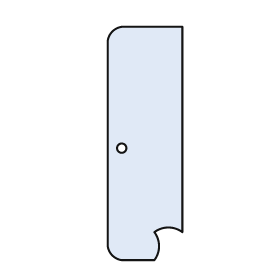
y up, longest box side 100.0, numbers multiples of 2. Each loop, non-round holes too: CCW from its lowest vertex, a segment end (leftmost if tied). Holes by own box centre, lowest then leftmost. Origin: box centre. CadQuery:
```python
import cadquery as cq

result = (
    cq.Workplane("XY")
    .moveTo(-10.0, -50.0)
    .lineTo(4.0, -50.0)
    .threePointArc((6.0, -44.0), (4.0, -38.0))
    .threePointArc((10.0, -36.0), (16.0, -38.0))
    .lineTo(16.0, 50.0)
    .lineTo(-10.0, 50.0)
    .threePointArc((-14.0, 48.0), (-16.0, 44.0))
    .lineTo(-16.0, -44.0)
    .threePointArc((-14.0, -48.0), (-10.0, -50.0))
    .close()
    .moveTo(-10.0, -2.0)
    .circle(2.0)
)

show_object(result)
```